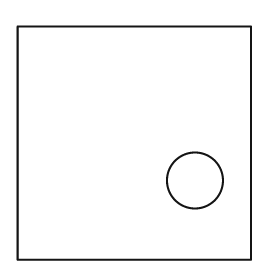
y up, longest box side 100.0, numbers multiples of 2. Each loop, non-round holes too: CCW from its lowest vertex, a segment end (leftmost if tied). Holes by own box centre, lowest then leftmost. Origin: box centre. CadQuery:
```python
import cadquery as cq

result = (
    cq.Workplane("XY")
    .moveTo(-50.0, -50.0)
    .lineTo(50.0, -50.0)
    .lineTo(50.0, 50.0)
    .lineTo(-50.0, 50.0)
    .close()
    .moveTo(26.0, -16.0)
    .circle(12.0)
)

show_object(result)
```